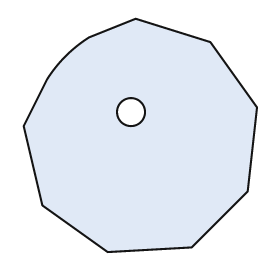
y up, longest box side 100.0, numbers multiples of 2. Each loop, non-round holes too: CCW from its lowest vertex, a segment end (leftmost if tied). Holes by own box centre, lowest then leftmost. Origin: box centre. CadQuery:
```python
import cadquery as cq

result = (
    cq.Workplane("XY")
    .moveTo(-14.0, -50.0)
    .lineTo(22.0, -48.0)
    .lineTo(46.0, -24.0)
    .lineTo(50.0, 12.0)
    .lineTo(30.0, 40.0)
    .lineTo(-2.0, 50.0)
    .lineTo(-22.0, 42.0)
    .threePointArc((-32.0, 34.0), (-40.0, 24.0))
    .lineTo(-50.0, 4.0)
    .lineTo(-42.0, -30.0)
    .close()
    .moveTo(-4.0, 10.0)
    .circle(6.0)
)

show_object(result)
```